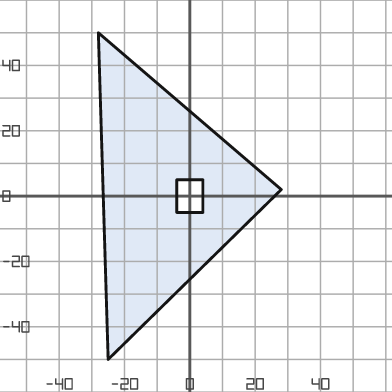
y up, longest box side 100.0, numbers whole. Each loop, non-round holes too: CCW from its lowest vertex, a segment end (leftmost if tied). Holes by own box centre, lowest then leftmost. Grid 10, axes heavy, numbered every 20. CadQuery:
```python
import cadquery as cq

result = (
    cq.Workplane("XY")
    .moveTo(-25.0, -50.0)
    .lineTo(28.0, 2.0)
    .lineTo(-28.0, 50.0)
    .close()
    .moveTo(-4.0, -5.0)
    .lineTo(4.0, -5.0)
    .lineTo(4.0, 5.0)
    .lineTo(-4.0, 5.0)
    .close()
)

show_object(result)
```